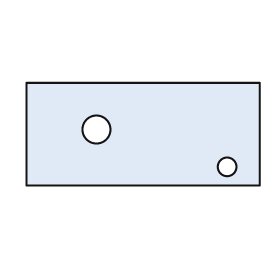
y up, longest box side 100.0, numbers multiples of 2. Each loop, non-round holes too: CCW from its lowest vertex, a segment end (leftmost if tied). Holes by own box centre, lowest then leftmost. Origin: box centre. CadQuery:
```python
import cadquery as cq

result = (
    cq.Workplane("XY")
    .moveTo(-50.0, -22.0)
    .lineTo(50.0, -22.0)
    .lineTo(50.0, 22.0)
    .lineTo(-50.0, 22.0)
    .close()
    .moveTo(36.0, -14.0)
    .circle(4.0)
    .moveTo(-20.0, 2.0)
    .circle(6.0)
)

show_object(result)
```